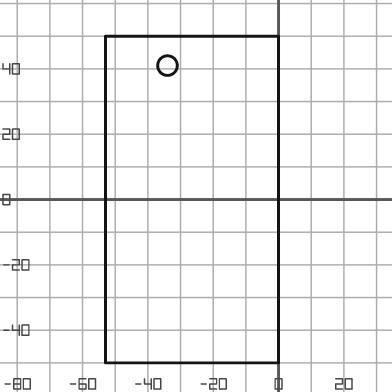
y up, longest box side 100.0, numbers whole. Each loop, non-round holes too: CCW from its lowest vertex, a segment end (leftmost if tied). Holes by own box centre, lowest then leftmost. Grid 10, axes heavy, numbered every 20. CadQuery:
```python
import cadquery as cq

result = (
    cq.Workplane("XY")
    .moveTo(-53.0, -50.0)
    .lineTo(0.0, -50.0)
    .lineTo(0.0, 50.0)
    .lineTo(-53.0, 50.0)
    .close()
    .moveTo(-34.0, 41.0)
    .circle(3.0)
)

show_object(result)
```